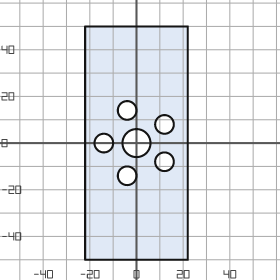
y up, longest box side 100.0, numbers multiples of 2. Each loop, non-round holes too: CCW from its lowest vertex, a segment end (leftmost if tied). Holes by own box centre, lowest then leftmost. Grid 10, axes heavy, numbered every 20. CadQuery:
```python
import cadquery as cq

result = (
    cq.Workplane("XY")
    .moveTo(-22.0, -50.0)
    .lineTo(22.0, -50.0)
    .lineTo(22.0, 50.0)
    .lineTo(-22.0, 50.0)
    .close()
    .moveTo(-4.0, -14.0)
    .circle(4.0)
    .moveTo(12.0, -8.0)
    .circle(4.0)
    .moveTo(-14.0, 0.0)
    .circle(4.0)
    .moveTo(0.0, 0.0)
    .circle(6.0)
    .moveTo(12.0, 8.0)
    .circle(4.0)
    .moveTo(-4.0, 14.0)
    .circle(4.0)
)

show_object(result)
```